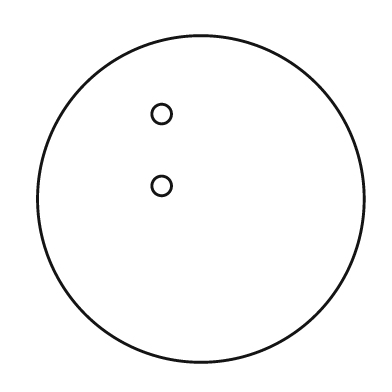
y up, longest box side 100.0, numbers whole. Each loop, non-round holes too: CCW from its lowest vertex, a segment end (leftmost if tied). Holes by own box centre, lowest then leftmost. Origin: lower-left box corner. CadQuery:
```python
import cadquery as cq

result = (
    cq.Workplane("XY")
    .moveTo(50.0, 50.0)
    .circle(50.0)
    .moveTo(38.0, 54.0)
    .circle(3.0)
    .moveTo(38.0, 76.0)
    .circle(3.0)
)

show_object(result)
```